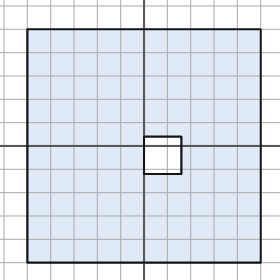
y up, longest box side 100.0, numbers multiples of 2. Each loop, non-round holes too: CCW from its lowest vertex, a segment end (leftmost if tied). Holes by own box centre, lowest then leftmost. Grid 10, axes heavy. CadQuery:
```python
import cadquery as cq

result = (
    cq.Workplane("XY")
    .moveTo(-50.0, -50.0)
    .lineTo(50.0, -50.0)
    .lineTo(50.0, 50.0)
    .lineTo(-50.0, 50.0)
    .close()
    .moveTo(0.0, -12.0)
    .lineTo(16.0, -12.0)
    .lineTo(16.0, 4.0)
    .lineTo(0.0, 4.0)
    .close()
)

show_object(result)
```